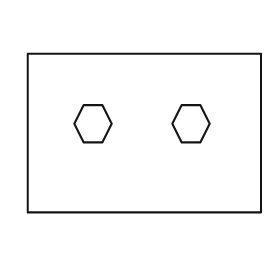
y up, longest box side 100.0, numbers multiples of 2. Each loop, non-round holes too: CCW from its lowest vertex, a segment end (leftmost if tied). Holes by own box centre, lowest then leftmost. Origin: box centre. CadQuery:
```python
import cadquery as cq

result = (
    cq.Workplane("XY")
    .moveTo(-50.0, -34.0)
    .lineTo(50.0, -34.0)
    .lineTo(50.0, 34.0)
    .lineTo(-50.0, 34.0)
    .close()
    .moveTo(-26.0, -4.0)
    .lineTo(-18.0, -4.0)
    .lineTo(-14.0, 4.0)
    .lineTo(-18.0, 12.0)
    .lineTo(-26.0, 12.0)
    .lineTo(-30.0, 4.0)
    .close()
    .moveTo(16.0, -4.0)
    .lineTo(24.0, -4.0)
    .lineTo(28.0, 4.0)
    .lineTo(24.0, 12.0)
    .lineTo(16.0, 12.0)
    .lineTo(12.0, 4.0)
    .close()
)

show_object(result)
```